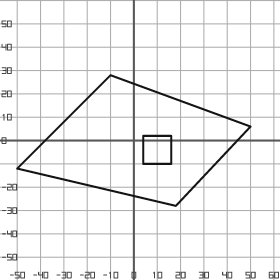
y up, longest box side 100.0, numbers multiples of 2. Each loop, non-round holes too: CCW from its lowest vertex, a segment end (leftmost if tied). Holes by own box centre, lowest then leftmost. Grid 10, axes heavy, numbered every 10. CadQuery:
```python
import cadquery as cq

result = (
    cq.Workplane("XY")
    .moveTo(18.0, -28.0)
    .lineTo(50.0, 6.0)
    .lineTo(-10.0, 28.0)
    .lineTo(-50.0, -12.0)
    .close()
    .moveTo(4.0, -10.0)
    .lineTo(16.0, -10.0)
    .lineTo(16.0, 2.0)
    .lineTo(4.0, 2.0)
    .close()
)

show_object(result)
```